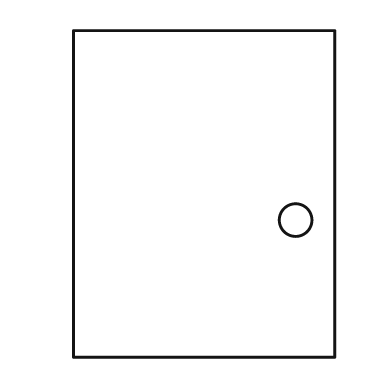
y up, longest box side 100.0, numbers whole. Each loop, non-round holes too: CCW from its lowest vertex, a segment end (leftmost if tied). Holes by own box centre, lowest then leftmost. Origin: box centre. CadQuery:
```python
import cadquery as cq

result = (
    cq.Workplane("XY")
    .moveTo(-40.0, -50.0)
    .lineTo(40.0, -50.0)
    .lineTo(40.0, 50.0)
    .lineTo(-40.0, 50.0)
    .close()
    .moveTo(28.0, -8.0)
    .circle(5.0)
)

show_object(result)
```